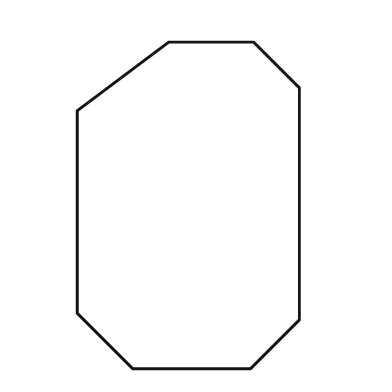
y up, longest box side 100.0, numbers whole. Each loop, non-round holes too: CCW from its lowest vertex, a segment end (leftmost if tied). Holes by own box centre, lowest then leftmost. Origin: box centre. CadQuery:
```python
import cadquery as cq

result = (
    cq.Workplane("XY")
    .moveTo(-17.0, -50.0)
    .lineTo(19.0, -50.0)
    .lineTo(34.0, -35.0)
    .lineTo(34.0, 36.0)
    .lineTo(20.0, 50.0)
    .lineTo(-6.0, 50.0)
    .lineTo(-34.0, 29.0)
    .lineTo(-34.0, -33.0)
    .close()
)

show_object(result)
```